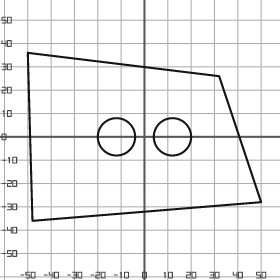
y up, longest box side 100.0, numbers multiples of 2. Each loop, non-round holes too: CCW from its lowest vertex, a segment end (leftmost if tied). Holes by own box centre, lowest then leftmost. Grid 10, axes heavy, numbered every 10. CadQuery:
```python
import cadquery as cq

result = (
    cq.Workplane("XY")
    .moveTo(-48.0, -36.0)
    .lineTo(50.0, -28.0)
    .lineTo(32.0, 26.0)
    .lineTo(-50.0, 36.0)
    .close()
    .moveTo(-12.0, 0.0)
    .circle(8.0)
    .moveTo(12.0, 0.0)
    .circle(8.0)
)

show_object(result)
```